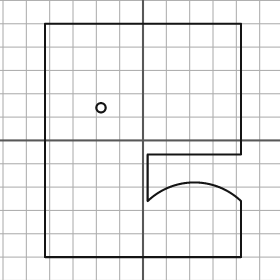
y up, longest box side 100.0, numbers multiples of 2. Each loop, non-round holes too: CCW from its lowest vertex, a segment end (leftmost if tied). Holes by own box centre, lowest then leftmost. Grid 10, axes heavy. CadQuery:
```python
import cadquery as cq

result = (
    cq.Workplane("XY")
    .moveTo(-42.0, -50.0)
    .lineTo(42.0, -50.0)
    .lineTo(42.0, -26.0)
    .threePointArc((22.0, -18.0), (2.0, -26.0))
    .lineTo(2.0, -6.0)
    .lineTo(42.0, -6.0)
    .lineTo(42.0, 50.0)
    .lineTo(-42.0, 50.0)
    .close()
    .moveTo(-18.0, 14.0)
    .circle(2.0)
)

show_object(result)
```